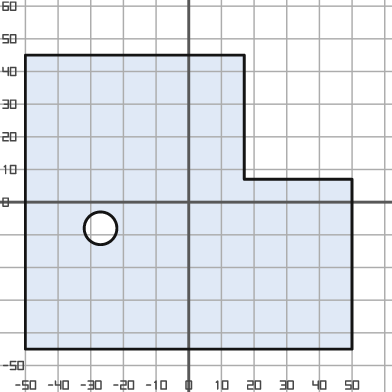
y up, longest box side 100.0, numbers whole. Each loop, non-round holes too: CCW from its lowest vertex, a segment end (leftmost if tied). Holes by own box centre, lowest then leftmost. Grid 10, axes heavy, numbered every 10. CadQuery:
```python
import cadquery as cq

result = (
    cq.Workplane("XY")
    .moveTo(-50.0, -45.0)
    .lineTo(50.0, -45.0)
    .lineTo(50.0, 7.0)
    .lineTo(17.0, 7.0)
    .lineTo(17.0, 45.0)
    .lineTo(-50.0, 45.0)
    .close()
    .moveTo(-27.0, -8.0)
    .circle(5.0)
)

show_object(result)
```